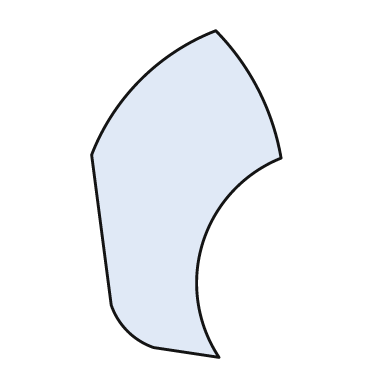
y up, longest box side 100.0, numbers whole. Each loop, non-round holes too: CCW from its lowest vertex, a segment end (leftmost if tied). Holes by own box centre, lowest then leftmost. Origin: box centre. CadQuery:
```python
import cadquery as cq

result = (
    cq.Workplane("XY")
    .moveTo(10.0, -50.0)
    .threePointArc((5.0, -15.0), (29.0, 11.0))
    .threePointArc((22.0, 32.0), (9.0, 50.0))
    .threePointArc((-14.0, 35.0), (-29.0, 12.0))
    .lineTo(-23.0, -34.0)
    .threePointArc((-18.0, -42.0), (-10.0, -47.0))
    .close()
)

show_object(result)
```